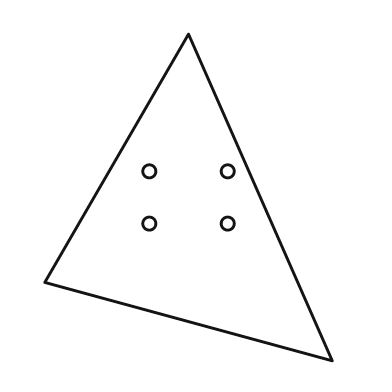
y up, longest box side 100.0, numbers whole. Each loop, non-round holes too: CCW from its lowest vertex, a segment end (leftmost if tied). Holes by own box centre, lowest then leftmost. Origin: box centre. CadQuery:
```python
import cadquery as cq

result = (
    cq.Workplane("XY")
    .moveTo(44.0, -50.0)
    .lineTo(0.0, 50.0)
    .lineTo(-44.0, -26.0)
    .close()
    .moveTo(-12.0, -8.0)
    .circle(2.0)
    .moveTo(12.0, -8.0)
    .circle(2.0)
    .moveTo(-12.0, 8.0)
    .circle(2.0)
    .moveTo(12.0, 8.0)
    .circle(2.0)
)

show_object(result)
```